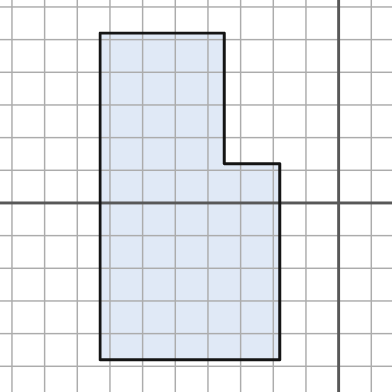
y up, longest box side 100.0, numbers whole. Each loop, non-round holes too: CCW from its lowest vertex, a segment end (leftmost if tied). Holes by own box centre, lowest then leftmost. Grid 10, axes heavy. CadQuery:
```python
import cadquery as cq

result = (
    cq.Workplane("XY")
    .moveTo(-73.0, -48.0)
    .lineTo(-18.0, -48.0)
    .lineTo(-18.0, 12.0)
    .lineTo(-35.0, 12.0)
    .lineTo(-35.0, 52.0)
    .lineTo(-73.0, 52.0)
    .close()
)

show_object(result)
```